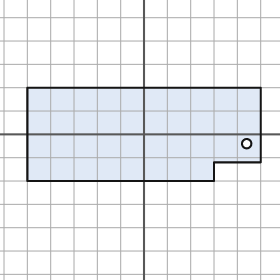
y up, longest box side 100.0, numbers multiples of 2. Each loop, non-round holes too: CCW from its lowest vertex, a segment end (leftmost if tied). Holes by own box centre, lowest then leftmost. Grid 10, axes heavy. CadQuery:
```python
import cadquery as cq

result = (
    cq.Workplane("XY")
    .moveTo(-50.0, -20.0)
    .lineTo(30.0, -20.0)
    .lineTo(30.0, -12.0)
    .lineTo(50.0, -12.0)
    .lineTo(50.0, 20.0)
    .lineTo(-50.0, 20.0)
    .close()
    .moveTo(44.0, -4.0)
    .circle(2.0)
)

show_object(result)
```